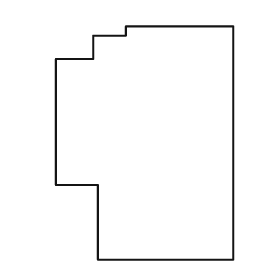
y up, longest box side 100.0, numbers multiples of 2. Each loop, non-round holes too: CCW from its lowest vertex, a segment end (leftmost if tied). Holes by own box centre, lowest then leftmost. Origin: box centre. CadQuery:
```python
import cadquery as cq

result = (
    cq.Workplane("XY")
    .moveTo(-20.0, -50.0)
    .lineTo(38.0, -50.0)
    .lineTo(38.0, 50.0)
    .lineTo(-8.0, 50.0)
    .lineTo(-8.0, 46.0)
    .lineTo(-22.0, 46.0)
    .lineTo(-22.0, 36.0)
    .lineTo(-38.0, 36.0)
    .lineTo(-38.0, -18.0)
    .lineTo(-20.0, -18.0)
    .close()
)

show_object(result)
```